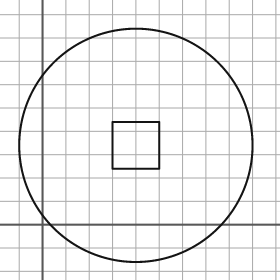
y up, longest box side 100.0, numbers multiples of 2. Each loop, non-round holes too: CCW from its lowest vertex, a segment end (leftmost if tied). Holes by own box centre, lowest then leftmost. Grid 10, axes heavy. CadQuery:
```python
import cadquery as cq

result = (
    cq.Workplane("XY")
    .moveTo(40.0, 34.0)
    .circle(50.0)
    .moveTo(30.0, 24.0)
    .lineTo(50.0, 24.0)
    .lineTo(50.0, 44.0)
    .lineTo(30.0, 44.0)
    .close()
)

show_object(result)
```